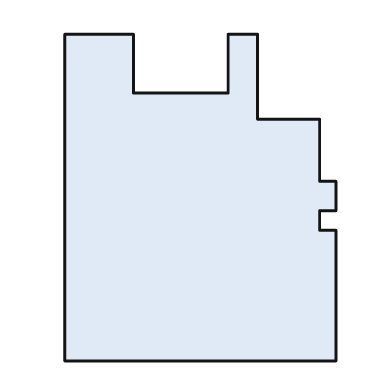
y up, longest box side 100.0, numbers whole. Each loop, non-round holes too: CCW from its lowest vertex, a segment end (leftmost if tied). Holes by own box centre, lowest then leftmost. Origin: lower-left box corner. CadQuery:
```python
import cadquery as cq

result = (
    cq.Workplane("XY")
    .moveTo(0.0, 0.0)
    .lineTo(83.0, 0.0)
    .lineTo(83.0, 40.0)
    .lineTo(78.0, 40.0)
    .lineTo(78.0, 46.0)
    .lineTo(83.0, 46.0)
    .lineTo(83.0, 55.0)
    .lineTo(78.0, 55.0)
    .lineTo(78.0, 74.0)
    .lineTo(59.0, 74.0)
    .lineTo(59.0, 100.0)
    .lineTo(50.0, 100.0)
    .lineTo(50.0, 82.0)
    .lineTo(21.0, 82.0)
    .lineTo(21.0, 100.0)
    .lineTo(0.0, 100.0)
    .close()
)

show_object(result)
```